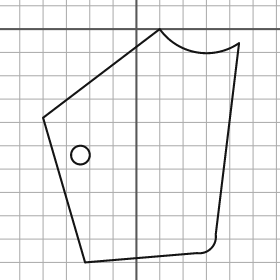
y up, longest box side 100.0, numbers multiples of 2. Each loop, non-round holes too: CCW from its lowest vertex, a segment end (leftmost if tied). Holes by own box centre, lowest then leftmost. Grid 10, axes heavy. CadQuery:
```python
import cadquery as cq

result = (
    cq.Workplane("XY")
    .moveTo(-22.0, -100.0)
    .lineTo(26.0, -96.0)
    .threePointArc((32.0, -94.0), (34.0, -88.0))
    .lineTo(44.0, -6.0)
    .threePointArc((26.0, -10.0), (10.0, 0.0))
    .lineTo(-40.0, -38.0)
    .close()
    .moveTo(-24.0, -54.0)
    .circle(4.0)
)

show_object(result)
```